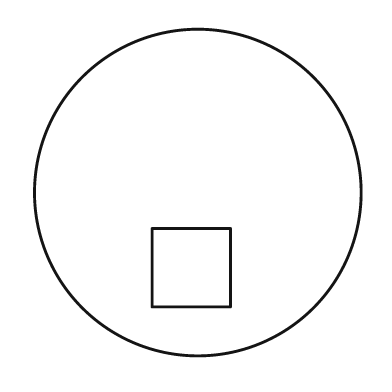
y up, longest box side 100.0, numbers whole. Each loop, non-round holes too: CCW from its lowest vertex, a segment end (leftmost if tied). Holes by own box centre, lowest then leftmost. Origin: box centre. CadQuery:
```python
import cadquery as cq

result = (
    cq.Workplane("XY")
    .moveTo(0.0, 0.0)
    .circle(50.0)
    .moveTo(-14.0, -35.0)
    .lineTo(10.0, -35.0)
    .lineTo(10.0, -11.0)
    .lineTo(-14.0, -11.0)
    .close()
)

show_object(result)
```